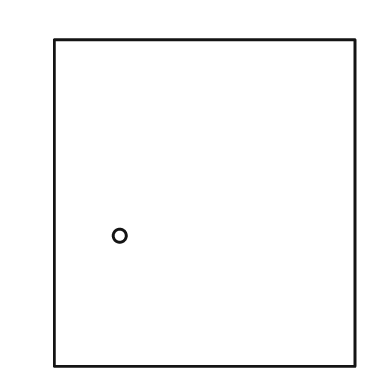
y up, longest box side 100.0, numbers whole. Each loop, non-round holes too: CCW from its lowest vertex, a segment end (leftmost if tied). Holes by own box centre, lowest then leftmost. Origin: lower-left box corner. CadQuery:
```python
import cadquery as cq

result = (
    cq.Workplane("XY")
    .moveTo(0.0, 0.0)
    .lineTo(92.0, 0.0)
    .lineTo(92.0, 100.0)
    .lineTo(0.0, 100.0)
    .close()
    .moveTo(20.0, 40.0)
    .circle(2.0)
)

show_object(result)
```